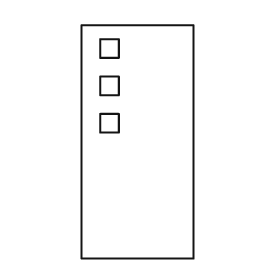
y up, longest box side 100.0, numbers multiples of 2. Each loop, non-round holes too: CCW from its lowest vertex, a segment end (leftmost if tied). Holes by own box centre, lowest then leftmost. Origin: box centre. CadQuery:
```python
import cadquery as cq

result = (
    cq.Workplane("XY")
    .moveTo(-24.0, -50.0)
    .lineTo(24.0, -50.0)
    .lineTo(24.0, 50.0)
    .lineTo(-24.0, 50.0)
    .close()
    .moveTo(-16.0, 4.0)
    .lineTo(-8.0, 4.0)
    .lineTo(-8.0, 12.0)
    .lineTo(-16.0, 12.0)
    .close()
    .moveTo(-16.0, 20.0)
    .lineTo(-8.0, 20.0)
    .lineTo(-8.0, 28.0)
    .lineTo(-16.0, 28.0)
    .close()
    .moveTo(-16.0, 36.0)
    .lineTo(-8.0, 36.0)
    .lineTo(-8.0, 44.0)
    .lineTo(-16.0, 44.0)
    .close()
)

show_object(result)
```